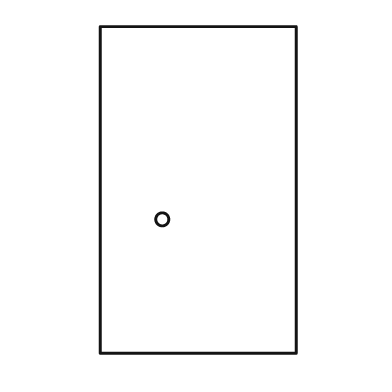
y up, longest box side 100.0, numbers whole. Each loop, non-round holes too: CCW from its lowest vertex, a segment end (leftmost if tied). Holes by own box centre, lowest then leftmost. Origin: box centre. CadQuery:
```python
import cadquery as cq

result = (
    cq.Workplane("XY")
    .moveTo(-30.0, -50.0)
    .lineTo(30.0, -50.0)
    .lineTo(30.0, 50.0)
    .lineTo(-30.0, 50.0)
    .close()
    .moveTo(-11.0, -9.0)
    .circle(2.0)
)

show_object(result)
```